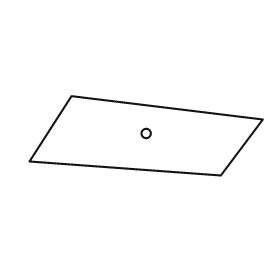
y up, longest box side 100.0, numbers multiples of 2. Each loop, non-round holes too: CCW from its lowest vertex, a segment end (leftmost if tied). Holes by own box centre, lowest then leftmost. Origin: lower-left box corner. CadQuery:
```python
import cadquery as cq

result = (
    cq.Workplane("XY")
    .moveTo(82.0, 0.0)
    .lineTo(100.0, 24.0)
    .lineTo(18.0, 34.0)
    .lineTo(0.0, 6.0)
    .close()
    .moveTo(50.0, 18.0)
    .circle(2.0)
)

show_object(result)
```